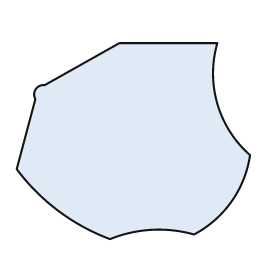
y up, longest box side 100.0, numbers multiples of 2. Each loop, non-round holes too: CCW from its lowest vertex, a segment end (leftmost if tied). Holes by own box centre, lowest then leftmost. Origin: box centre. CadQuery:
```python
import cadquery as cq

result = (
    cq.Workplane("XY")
    .moveTo(-10.0, -42.0)
    .threePointArc((8.0, -38.0), (26.0, -40.0))
    .threePointArc((42.0, -26.0), (50.0, -6.0))
    .threePointArc((36.0, 16.0), (36.0, 42.0))
    .lineTo(-6.0, 42.0)
    .lineTo(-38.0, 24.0)
    .threePointArc((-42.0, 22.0), (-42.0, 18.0))
    .lineTo(-50.0, -12.0)
    .threePointArc((-32.0, -30.0), (-10.0, -42.0))
    .close()
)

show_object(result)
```